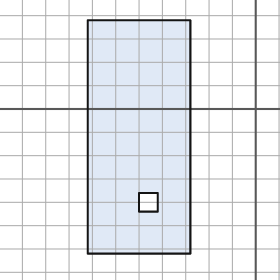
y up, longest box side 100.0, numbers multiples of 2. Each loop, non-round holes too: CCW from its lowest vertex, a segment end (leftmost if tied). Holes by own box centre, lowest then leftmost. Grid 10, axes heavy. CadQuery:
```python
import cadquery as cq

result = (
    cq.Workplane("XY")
    .moveTo(-72.0, -62.0)
    .lineTo(-28.0, -62.0)
    .lineTo(-28.0, 38.0)
    .lineTo(-72.0, 38.0)
    .close()
    .moveTo(-50.0, -44.0)
    .lineTo(-42.0, -44.0)
    .lineTo(-42.0, -36.0)
    .lineTo(-50.0, -36.0)
    .close()
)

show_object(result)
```